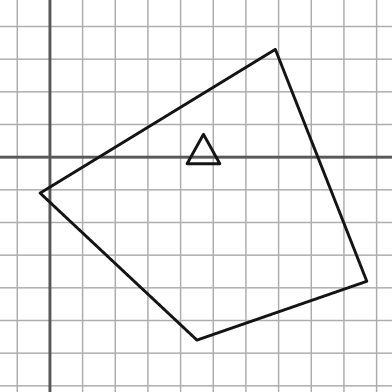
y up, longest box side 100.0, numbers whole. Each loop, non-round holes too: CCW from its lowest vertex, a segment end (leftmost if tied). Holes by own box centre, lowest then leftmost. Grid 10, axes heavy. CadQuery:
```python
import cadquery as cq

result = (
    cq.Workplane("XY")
    .moveTo(45.0, -56.0)
    .lineTo(97.0, -38.0)
    .lineTo(69.0, 33.0)
    .lineTo(-3.0, -11.0)
    .close()
    .moveTo(42.0, -2.0)
    .lineTo(52.0, -2.0)
    .lineTo(47.0, 7.0)
    .close()
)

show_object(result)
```